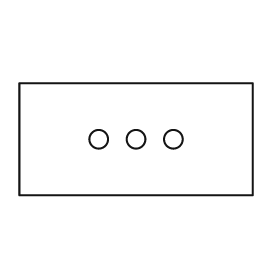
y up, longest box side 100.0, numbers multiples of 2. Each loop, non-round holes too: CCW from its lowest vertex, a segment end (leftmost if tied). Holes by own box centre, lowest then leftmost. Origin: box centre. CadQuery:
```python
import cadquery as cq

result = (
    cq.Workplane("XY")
    .moveTo(-50.0, -24.0)
    .lineTo(50.0, -24.0)
    .lineTo(50.0, 24.0)
    .lineTo(-50.0, 24.0)
    .close()
    .moveTo(-16.0, 0.0)
    .circle(4.0)
    .moveTo(0.0, 0.0)
    .circle(4.0)
    .moveTo(16.0, 0.0)
    .circle(4.0)
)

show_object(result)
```